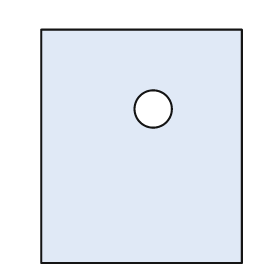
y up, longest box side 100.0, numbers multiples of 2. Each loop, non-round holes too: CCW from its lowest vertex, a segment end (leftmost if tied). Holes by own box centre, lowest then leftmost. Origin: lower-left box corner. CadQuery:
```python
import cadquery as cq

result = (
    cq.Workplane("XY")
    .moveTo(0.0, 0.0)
    .lineTo(86.0, 0.0)
    .lineTo(86.0, 100.0)
    .lineTo(0.0, 100.0)
    .close()
    .moveTo(48.0, 66.0)
    .circle(8.0)
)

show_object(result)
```